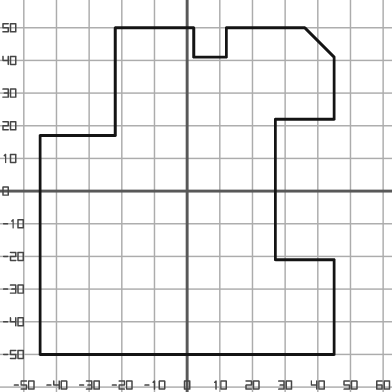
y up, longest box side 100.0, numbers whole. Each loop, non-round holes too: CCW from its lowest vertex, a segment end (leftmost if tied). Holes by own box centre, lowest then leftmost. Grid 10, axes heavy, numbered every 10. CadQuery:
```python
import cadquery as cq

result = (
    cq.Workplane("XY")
    .moveTo(-45.0, -50.0)
    .lineTo(45.0, -50.0)
    .lineTo(45.0, -21.0)
    .lineTo(27.0, -21.0)
    .lineTo(27.0, 22.0)
    .lineTo(45.0, 22.0)
    .lineTo(45.0, 41.0)
    .lineTo(36.0, 50.0)
    .lineTo(12.0, 50.0)
    .lineTo(12.0, 41.0)
    .lineTo(2.0, 41.0)
    .lineTo(2.0, 50.0)
    .lineTo(-22.0, 50.0)
    .lineTo(-22.0, 17.0)
    .lineTo(-45.0, 17.0)
    .close()
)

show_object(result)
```